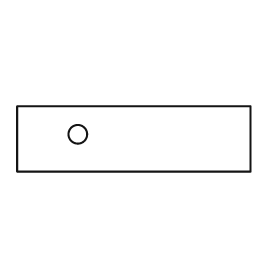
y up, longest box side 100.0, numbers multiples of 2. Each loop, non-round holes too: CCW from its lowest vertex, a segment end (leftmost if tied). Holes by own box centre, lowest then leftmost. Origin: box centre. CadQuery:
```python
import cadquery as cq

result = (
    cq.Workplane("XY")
    .moveTo(-50.0, -14.0)
    .lineTo(50.0, -14.0)
    .lineTo(50.0, 14.0)
    .lineTo(-50.0, 14.0)
    .close()
    .moveTo(-24.0, 2.0)
    .circle(4.0)
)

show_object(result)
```